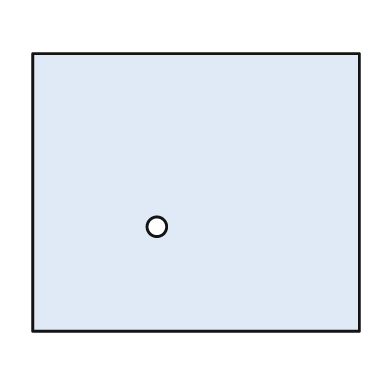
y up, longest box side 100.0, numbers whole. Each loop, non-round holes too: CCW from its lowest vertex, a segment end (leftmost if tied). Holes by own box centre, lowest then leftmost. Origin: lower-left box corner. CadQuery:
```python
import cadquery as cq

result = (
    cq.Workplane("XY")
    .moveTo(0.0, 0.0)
    .lineTo(100.0, 0.0)
    .lineTo(100.0, 85.0)
    .lineTo(0.0, 85.0)
    .close()
    .moveTo(38.0, 32.0)
    .circle(3.0)
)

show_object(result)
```